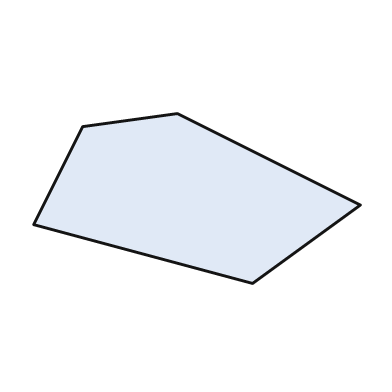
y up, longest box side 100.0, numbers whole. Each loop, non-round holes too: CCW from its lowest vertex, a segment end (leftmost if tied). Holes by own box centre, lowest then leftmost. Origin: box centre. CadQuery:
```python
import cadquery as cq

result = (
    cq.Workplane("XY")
    .moveTo(17.0, -26.0)
    .lineTo(50.0, -2.0)
    .lineTo(-6.0, 26.0)
    .lineTo(-35.0, 22.0)
    .lineTo(-50.0, -8.0)
    .close()
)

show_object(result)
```